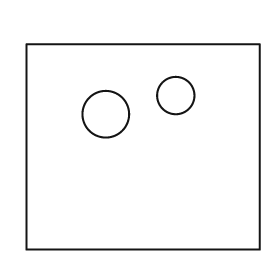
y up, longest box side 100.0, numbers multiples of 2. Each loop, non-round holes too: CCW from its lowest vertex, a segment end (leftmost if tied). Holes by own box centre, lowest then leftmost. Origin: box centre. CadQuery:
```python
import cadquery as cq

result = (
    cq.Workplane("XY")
    .moveTo(-50.0, -44.0)
    .lineTo(50.0, -44.0)
    .lineTo(50.0, 44.0)
    .lineTo(-50.0, 44.0)
    .close()
    .moveTo(-16.0, 14.0)
    .circle(10.0)
    .moveTo(14.0, 22.0)
    .circle(8.0)
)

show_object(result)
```